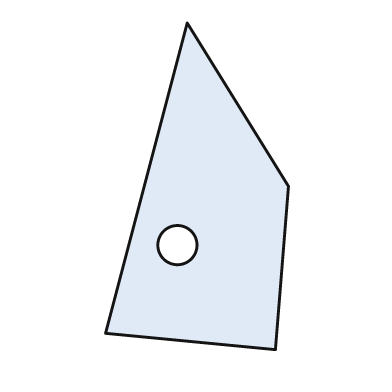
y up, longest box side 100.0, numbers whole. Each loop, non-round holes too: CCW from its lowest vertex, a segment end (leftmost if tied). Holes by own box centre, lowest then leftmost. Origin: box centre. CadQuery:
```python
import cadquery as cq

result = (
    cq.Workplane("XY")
    .moveTo(24.0, -50.0)
    .lineTo(28.0, 0.0)
    .lineTo(-3.0, 50.0)
    .lineTo(-28.0, -45.0)
    .close()
    .moveTo(-6.0, -18.0)
    .circle(6.0)
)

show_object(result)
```